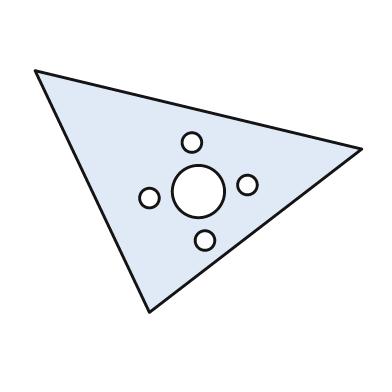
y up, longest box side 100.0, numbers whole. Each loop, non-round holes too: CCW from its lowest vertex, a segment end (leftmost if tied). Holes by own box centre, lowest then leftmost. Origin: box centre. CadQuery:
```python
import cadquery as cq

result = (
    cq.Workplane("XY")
    .moveTo(-15.0, -37.0)
    .lineTo(50.0, 13.0)
    .lineTo(-50.0, 37.0)
    .close()
    .moveTo(2.0, -15.0)
    .circle(3.0)
    .moveTo(-15.0, -2.0)
    .circle(3.0)
    .moveTo(0.0, 0.0)
    .circle(8.0)
    .moveTo(15.0, 2.0)
    .circle(3.0)
    .moveTo(-2.0, 15.0)
    .circle(3.0)
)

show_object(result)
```